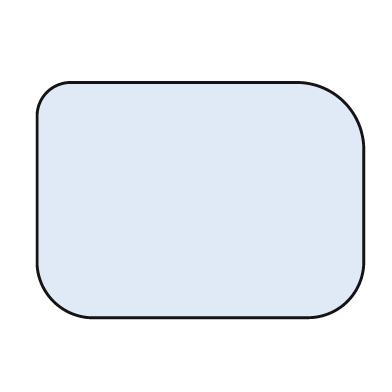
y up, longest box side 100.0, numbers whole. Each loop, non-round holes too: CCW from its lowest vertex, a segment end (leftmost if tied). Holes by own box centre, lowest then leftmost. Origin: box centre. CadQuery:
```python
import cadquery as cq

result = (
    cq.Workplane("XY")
    .moveTo(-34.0, -36.0)
    .lineTo(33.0, -36.0)
    .threePointArc((45.0, -31.0), (50.0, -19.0))
    .lineTo(50.0, 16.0)
    .threePointArc((44.0, 30.0), (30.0, 36.0))
    .lineTo(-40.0, 36.0)
    .threePointArc((-47.0, 33.0), (-50.0, 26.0))
    .lineTo(-50.0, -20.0)
    .threePointArc((-45.0, -31.0), (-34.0, -36.0))
    .close()
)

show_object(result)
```